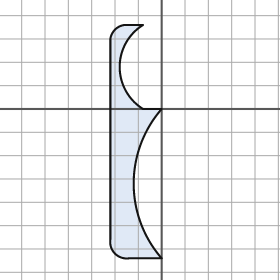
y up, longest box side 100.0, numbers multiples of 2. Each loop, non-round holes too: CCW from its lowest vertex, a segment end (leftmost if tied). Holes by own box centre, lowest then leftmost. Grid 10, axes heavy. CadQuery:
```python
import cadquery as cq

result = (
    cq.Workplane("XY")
    .moveTo(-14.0, -64.0)
    .lineTo(0.0, -64.0)
    .threePointArc((-12.0, -32.0), (0.0, 0.0))
    .lineTo(-8.0, 0.0)
    .threePointArc((-18.0, 18.0), (-8.0, 36.0))
    .lineTo(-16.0, 36.0)
    .threePointArc((-20.0, 34.0), (-22.0, 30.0))
    .lineTo(-22.0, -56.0)
    .threePointArc((-20.0, -62.0), (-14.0, -64.0))
    .close()
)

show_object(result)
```